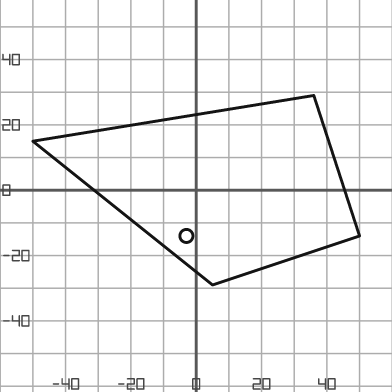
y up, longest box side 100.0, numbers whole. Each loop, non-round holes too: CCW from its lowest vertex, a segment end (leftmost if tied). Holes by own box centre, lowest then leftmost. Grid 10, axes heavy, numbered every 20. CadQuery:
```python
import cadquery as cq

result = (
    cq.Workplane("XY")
    .moveTo(5.0, -29.0)
    .lineTo(50.0, -14.0)
    .lineTo(36.0, 29.0)
    .lineTo(-50.0, 15.0)
    .close()
    .moveTo(-3.0, -14.0)
    .circle(2.0)
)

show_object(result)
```